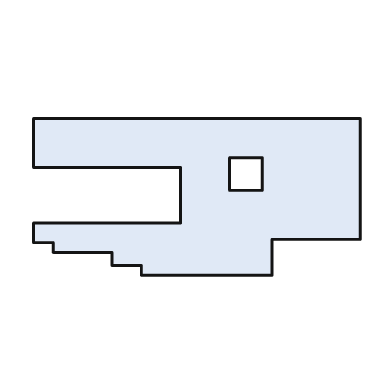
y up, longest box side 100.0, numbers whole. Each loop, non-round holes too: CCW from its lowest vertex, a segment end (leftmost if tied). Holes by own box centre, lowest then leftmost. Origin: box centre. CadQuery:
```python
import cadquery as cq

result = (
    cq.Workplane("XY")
    .moveTo(-17.0, -24.0)
    .lineTo(23.0, -24.0)
    .lineTo(23.0, -13.0)
    .lineTo(50.0, -13.0)
    .lineTo(50.0, 24.0)
    .lineTo(-50.0, 24.0)
    .lineTo(-50.0, 9.0)
    .lineTo(-5.0, 9.0)
    .lineTo(-5.0, -8.0)
    .lineTo(-50.0, -8.0)
    .lineTo(-50.0, -14.0)
    .lineTo(-44.0, -14.0)
    .lineTo(-44.0, -17.0)
    .lineTo(-26.0, -17.0)
    .lineTo(-26.0, -21.0)
    .lineTo(-17.0, -21.0)
    .close()
    .moveTo(10.0, 2.0)
    .lineTo(20.0, 2.0)
    .lineTo(20.0, 12.0)
    .lineTo(10.0, 12.0)
    .close()
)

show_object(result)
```